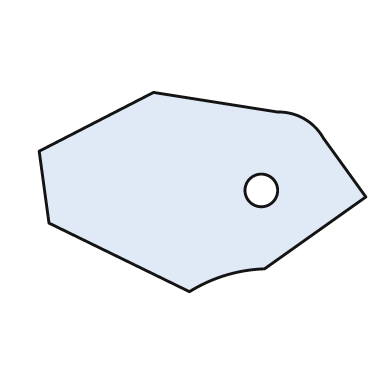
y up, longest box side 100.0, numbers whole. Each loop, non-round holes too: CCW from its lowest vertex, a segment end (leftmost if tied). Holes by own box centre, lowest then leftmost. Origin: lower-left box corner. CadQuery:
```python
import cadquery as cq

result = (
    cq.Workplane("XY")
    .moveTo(46.0, 0.0)
    .threePointArc((57.0, 5.0), (69.0, 7.0))
    .lineTo(100.0, 29.0)
    .lineTo(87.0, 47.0)
    .threePointArc((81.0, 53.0), (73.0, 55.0))
    .lineTo(35.0, 61.0)
    .lineTo(0.0, 43.0)
    .lineTo(3.0, 21.0)
    .close()
    .moveTo(68.0, 31.0)
    .circle(5.0)
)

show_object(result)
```